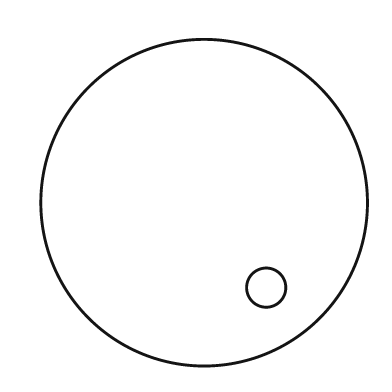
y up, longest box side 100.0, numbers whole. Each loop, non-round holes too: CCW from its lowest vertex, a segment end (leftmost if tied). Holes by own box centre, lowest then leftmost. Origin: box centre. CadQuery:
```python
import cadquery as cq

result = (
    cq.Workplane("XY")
    .moveTo(0.0, 0.0)
    .circle(50.0)
    .moveTo(19.0, -26.0)
    .circle(6.0)
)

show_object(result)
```